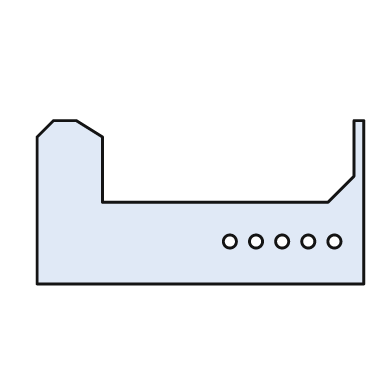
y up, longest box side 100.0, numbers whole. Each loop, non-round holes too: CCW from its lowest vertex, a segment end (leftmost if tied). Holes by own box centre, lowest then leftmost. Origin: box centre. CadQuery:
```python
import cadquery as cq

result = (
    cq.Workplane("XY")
    .moveTo(-50.0, -25.0)
    .lineTo(50.0, -25.0)
    .lineTo(50.0, 25.0)
    .lineTo(47.0, 25.0)
    .lineTo(47.0, 8.0)
    .lineTo(39.0, 0.0)
    .lineTo(-30.0, 0.0)
    .lineTo(-30.0, 20.0)
    .lineTo(-38.0, 25.0)
    .lineTo(-45.0, 25.0)
    .lineTo(-50.0, 20.0)
    .close()
    .moveTo(9.0, -12.0)
    .circle(2.0)
    .moveTo(17.0, -12.0)
    .circle(2.0)
    .moveTo(25.0, -12.0)
    .circle(2.0)
    .moveTo(33.0, -12.0)
    .circle(2.0)
    .moveTo(41.0, -12.0)
    .circle(2.0)
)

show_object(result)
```